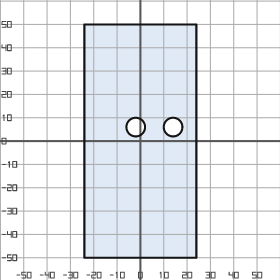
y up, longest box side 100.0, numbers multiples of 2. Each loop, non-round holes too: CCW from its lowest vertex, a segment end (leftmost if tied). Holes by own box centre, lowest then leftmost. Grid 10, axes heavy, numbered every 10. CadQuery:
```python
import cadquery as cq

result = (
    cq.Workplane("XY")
    .moveTo(-24.0, -50.0)
    .lineTo(24.0, -50.0)
    .lineTo(24.0, 50.0)
    .lineTo(-24.0, 50.0)
    .close()
    .moveTo(-2.0, 6.0)
    .circle(4.0)
    .moveTo(14.0, 6.0)
    .circle(4.0)
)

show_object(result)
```